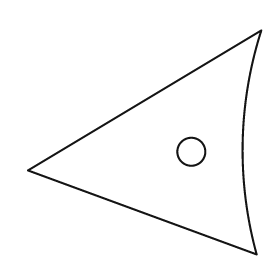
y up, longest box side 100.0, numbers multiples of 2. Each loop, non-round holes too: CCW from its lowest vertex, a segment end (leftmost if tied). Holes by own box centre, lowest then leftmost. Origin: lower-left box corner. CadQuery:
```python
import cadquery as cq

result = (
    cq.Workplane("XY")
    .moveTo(98.0, 0.0)
    .threePointArc((92.0, 48.0), (100.0, 96.0))
    .lineTo(0.0, 36.0)
    .close()
    .moveTo(70.0, 44.0)
    .circle(6.0)
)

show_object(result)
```